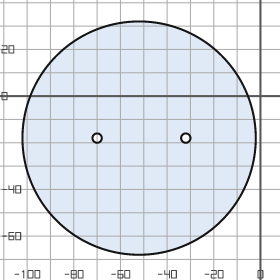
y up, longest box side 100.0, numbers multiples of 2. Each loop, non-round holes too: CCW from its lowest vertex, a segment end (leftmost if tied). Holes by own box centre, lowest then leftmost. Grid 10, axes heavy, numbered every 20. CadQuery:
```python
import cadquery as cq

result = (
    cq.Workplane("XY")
    .moveTo(-52.0, -18.0)
    .circle(50.0)
    .moveTo(-70.0, -18.0)
    .circle(2.0)
    .moveTo(-32.0, -18.0)
    .circle(2.0)
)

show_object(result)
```